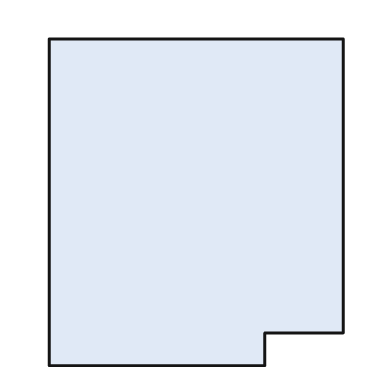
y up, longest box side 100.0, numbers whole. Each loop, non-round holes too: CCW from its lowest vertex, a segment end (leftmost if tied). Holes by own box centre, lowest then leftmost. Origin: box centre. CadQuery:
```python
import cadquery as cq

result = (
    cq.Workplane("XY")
    .moveTo(-45.0, -50.0)
    .lineTo(21.0, -50.0)
    .lineTo(21.0, -40.0)
    .lineTo(45.0, -40.0)
    .lineTo(45.0, 50.0)
    .lineTo(-45.0, 50.0)
    .close()
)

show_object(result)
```